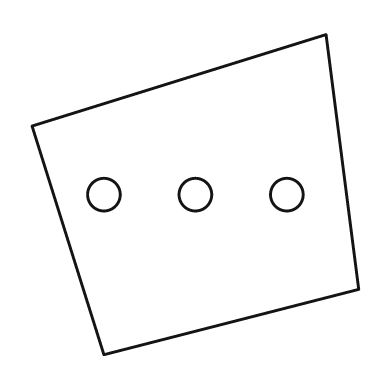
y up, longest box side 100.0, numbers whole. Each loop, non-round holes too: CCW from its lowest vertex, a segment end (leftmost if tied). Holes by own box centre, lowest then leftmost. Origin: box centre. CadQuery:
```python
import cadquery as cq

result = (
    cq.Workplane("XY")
    .moveTo(-28.0, -49.0)
    .lineTo(50.0, -29.0)
    .lineTo(40.0, 49.0)
    .lineTo(-50.0, 21.0)
    .close()
    .moveTo(-28.0, 0.0)
    .circle(5.0)
    .moveTo(0.0, 0.0)
    .circle(5.0)
    .moveTo(28.0, 0.0)
    .circle(5.0)
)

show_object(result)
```